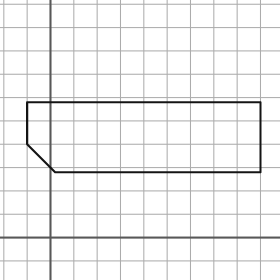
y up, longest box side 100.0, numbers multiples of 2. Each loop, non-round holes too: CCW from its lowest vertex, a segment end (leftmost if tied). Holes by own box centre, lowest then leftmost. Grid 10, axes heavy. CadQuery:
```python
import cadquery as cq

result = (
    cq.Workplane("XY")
    .moveTo(2.0, 28.0)
    .lineTo(90.0, 28.0)
    .lineTo(90.0, 58.0)
    .lineTo(-10.0, 58.0)
    .lineTo(-10.0, 40.0)
    .close()
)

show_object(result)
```